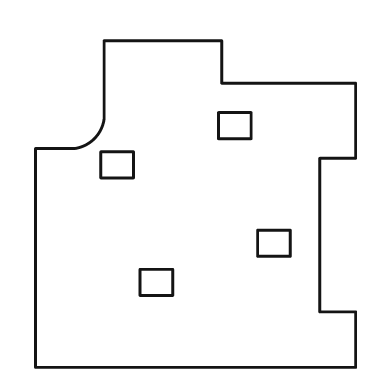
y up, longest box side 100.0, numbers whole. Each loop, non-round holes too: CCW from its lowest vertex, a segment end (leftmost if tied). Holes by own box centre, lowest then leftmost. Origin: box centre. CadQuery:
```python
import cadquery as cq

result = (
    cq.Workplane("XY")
    .moveTo(-49.0, -50.0)
    .lineTo(49.0, -50.0)
    .lineTo(49.0, -33.0)
    .lineTo(38.0, -33.0)
    .lineTo(38.0, 14.0)
    .lineTo(49.0, 14.0)
    .lineTo(49.0, 37.0)
    .lineTo(8.0, 37.0)
    .lineTo(8.0, 50.0)
    .lineTo(-28.0, 50.0)
    .lineTo(-28.0, 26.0)
    .threePointArc((-31.0, 20.0), (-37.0, 17.0))
    .lineTo(-49.0, 17.0)
    .close()
    .moveTo(-17.0, -28.0)
    .lineTo(-7.0, -28.0)
    .lineTo(-7.0, -20.0)
    .lineTo(-17.0, -20.0)
    .close()
    .moveTo(19.0, -16.0)
    .lineTo(29.0, -16.0)
    .lineTo(29.0, -8.0)
    .lineTo(19.0, -8.0)
    .close()
    .moveTo(-29.0, 8.0)
    .lineTo(-19.0, 8.0)
    .lineTo(-19.0, 16.0)
    .lineTo(-29.0, 16.0)
    .close()
    .moveTo(7.0, 20.0)
    .lineTo(17.0, 20.0)
    .lineTo(17.0, 28.0)
    .lineTo(7.0, 28.0)
    .close()
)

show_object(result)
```